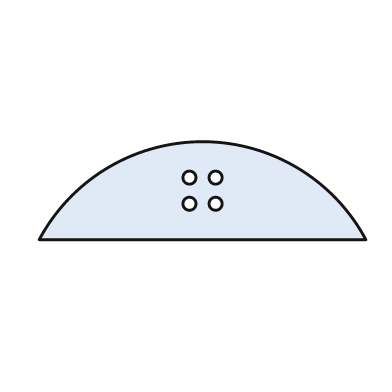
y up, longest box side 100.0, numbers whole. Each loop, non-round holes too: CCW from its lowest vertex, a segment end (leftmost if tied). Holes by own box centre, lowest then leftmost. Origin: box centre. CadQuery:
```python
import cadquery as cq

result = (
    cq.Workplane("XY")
    .moveTo(-50.0, -15.0)
    .lineTo(50.0, -15.0)
    .threePointArc((0.0, 15.0), (-50.0, -15.0))
    .close()
    .moveTo(-4.0, -4.0)
    .circle(2.0)
    .moveTo(4.0, -4.0)
    .circle(2.0)
    .moveTo(-4.0, 4.0)
    .circle(2.0)
    .moveTo(4.0, 4.0)
    .circle(2.0)
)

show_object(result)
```